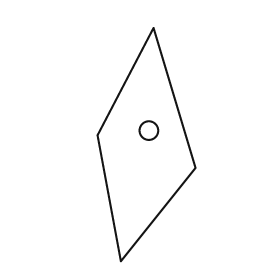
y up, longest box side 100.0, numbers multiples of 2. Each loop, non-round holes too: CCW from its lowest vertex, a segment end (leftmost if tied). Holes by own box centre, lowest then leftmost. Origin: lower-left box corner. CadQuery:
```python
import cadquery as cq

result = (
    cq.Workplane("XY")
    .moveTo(10.0, 0.0)
    .lineTo(42.0, 40.0)
    .lineTo(24.0, 100.0)
    .lineTo(0.0, 54.0)
    .close()
    .moveTo(22.0, 56.0)
    .circle(4.0)
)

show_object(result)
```